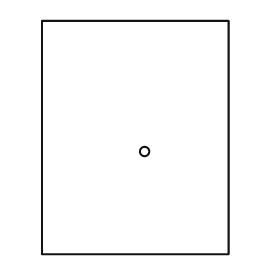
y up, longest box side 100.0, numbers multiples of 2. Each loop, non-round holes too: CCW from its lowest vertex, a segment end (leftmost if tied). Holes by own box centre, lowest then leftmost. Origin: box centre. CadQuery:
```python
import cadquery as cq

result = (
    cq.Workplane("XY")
    .moveTo(-40.0, -50.0)
    .lineTo(40.0, -50.0)
    .lineTo(40.0, 50.0)
    .lineTo(-40.0, 50.0)
    .close()
    .moveTo(4.0, -6.0)
    .circle(2.0)
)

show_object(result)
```